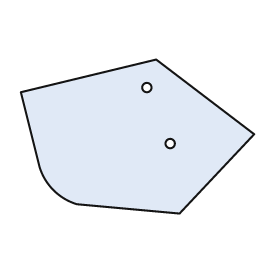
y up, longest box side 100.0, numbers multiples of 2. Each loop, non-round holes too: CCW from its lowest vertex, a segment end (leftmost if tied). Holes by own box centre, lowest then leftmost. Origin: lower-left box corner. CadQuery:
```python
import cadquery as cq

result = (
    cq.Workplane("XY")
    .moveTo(68.0, 0.0)
    .lineTo(100.0, 34.0)
    .lineTo(58.0, 66.0)
    .lineTo(0.0, 52.0)
    .lineTo(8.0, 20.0)
    .threePointArc((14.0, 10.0), (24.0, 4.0))
    .close()
    .moveTo(64.0, 30.0)
    .circle(2.0)
    .moveTo(54.0, 54.0)
    .circle(2.0)
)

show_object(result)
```